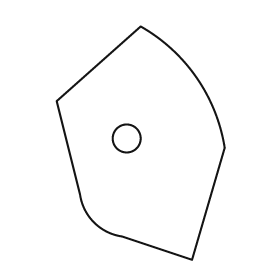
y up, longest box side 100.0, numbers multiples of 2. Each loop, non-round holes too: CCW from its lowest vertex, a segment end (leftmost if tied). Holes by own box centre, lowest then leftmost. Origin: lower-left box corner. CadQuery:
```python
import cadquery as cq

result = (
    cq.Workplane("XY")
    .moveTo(58.0, 0.0)
    .lineTo(72.0, 48.0)
    .threePointArc((60.0, 78.0), (36.0, 100.0))
    .lineTo(0.0, 68.0)
    .lineTo(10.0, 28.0)
    .threePointArc((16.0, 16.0), (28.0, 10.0))
    .close()
    .moveTo(30.0, 52.0)
    .circle(6.0)
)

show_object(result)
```